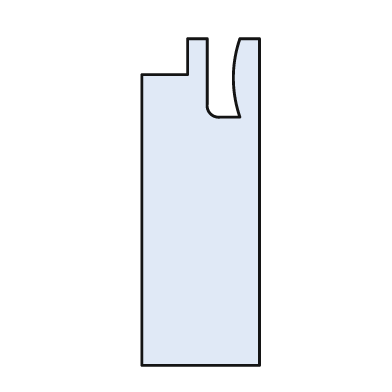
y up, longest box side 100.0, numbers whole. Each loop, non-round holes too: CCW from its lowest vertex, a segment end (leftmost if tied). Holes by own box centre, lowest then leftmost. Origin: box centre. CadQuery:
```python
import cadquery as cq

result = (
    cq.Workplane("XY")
    .moveTo(-18.0, -50.0)
    .lineTo(18.0, -50.0)
    .lineTo(18.0, 50.0)
    .lineTo(12.0, 50.0)
    .threePointArc((10.0, 38.0), (12.0, 26.0))
    .lineTo(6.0, 26.0)
    .threePointArc((3.0, 27.0), (2.0, 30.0))
    .lineTo(2.0, 50.0)
    .lineTo(-4.0, 50.0)
    .lineTo(-4.0, 39.0)
    .lineTo(-18.0, 39.0)
    .close()
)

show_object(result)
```